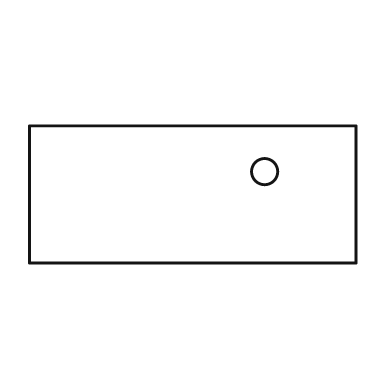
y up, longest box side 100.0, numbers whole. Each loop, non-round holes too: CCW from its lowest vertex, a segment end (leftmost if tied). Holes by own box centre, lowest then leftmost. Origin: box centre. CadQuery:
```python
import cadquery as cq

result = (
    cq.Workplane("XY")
    .moveTo(-50.0, -21.0)
    .lineTo(50.0, -21.0)
    .lineTo(50.0, 21.0)
    .lineTo(-50.0, 21.0)
    .close()
    .moveTo(22.0, 7.0)
    .circle(4.0)
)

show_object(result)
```